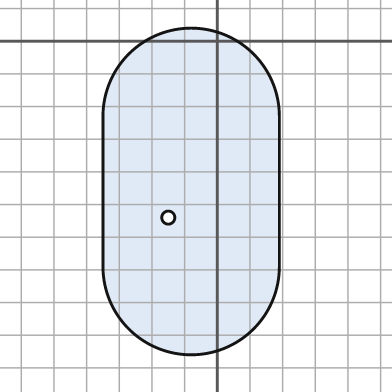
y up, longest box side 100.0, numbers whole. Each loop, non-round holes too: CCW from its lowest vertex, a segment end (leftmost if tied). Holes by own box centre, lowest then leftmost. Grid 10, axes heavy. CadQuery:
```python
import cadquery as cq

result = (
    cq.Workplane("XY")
    .moveTo(-35.0, -69.0)
    .threePointArc((-8.0, -96.0), (19.0, -69.0))
    .lineTo(19.0, -23.0)
    .threePointArc((-8.0, 4.0), (-35.0, -23.0))
    .close()
    .moveTo(-15.0, -54.0)
    .circle(2.0)
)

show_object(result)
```